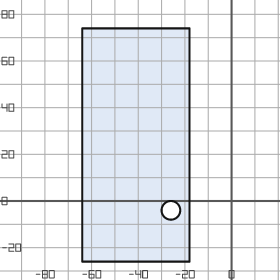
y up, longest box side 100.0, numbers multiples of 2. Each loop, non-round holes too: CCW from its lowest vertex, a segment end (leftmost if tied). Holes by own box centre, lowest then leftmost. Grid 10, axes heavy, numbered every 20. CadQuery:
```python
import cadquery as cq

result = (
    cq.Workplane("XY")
    .moveTo(-64.0, -26.0)
    .lineTo(-18.0, -26.0)
    .lineTo(-18.0, 74.0)
    .lineTo(-64.0, 74.0)
    .close()
    .moveTo(-26.0, -4.0)
    .circle(4.0)
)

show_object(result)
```